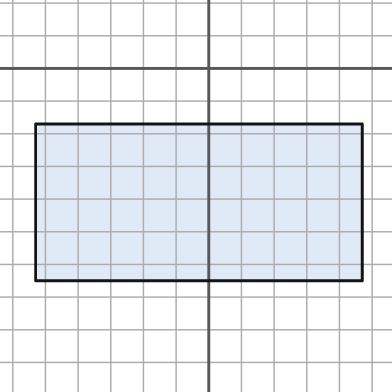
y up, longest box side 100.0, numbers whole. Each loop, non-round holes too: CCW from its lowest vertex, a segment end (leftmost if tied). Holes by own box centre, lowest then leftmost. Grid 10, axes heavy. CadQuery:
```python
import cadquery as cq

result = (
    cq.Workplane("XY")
    .moveTo(-53.0, -65.0)
    .lineTo(47.0, -65.0)
    .lineTo(47.0, -17.0)
    .lineTo(-53.0, -17.0)
    .close()
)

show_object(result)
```